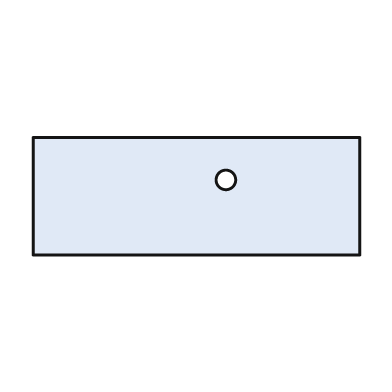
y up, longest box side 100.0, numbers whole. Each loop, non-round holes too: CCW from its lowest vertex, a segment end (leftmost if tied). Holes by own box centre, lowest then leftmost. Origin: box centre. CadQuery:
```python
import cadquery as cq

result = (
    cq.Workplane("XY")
    .moveTo(-50.0, -18.0)
    .lineTo(50.0, -18.0)
    .lineTo(50.0, 18.0)
    .lineTo(-50.0, 18.0)
    .close()
    .moveTo(9.0, 5.0)
    .circle(3.0)
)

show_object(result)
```